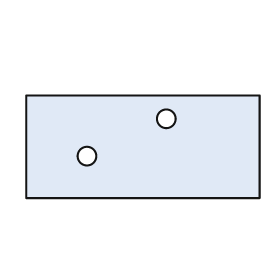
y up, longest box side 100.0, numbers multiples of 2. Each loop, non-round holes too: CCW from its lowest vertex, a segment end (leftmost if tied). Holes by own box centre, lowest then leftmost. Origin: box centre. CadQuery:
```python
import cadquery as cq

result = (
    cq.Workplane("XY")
    .moveTo(-50.0, -22.0)
    .lineTo(50.0, -22.0)
    .lineTo(50.0, 22.0)
    .lineTo(-50.0, 22.0)
    .close()
    .moveTo(-24.0, -4.0)
    .circle(4.0)
    .moveTo(10.0, 12.0)
    .circle(4.0)
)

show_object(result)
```